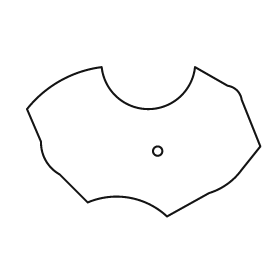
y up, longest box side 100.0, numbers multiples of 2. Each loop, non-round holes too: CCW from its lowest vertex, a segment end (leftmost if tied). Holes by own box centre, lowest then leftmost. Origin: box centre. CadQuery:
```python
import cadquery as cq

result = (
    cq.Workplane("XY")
    .moveTo(10.0, -32.0)
    .lineTo(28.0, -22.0)
    .threePointArc((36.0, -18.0), (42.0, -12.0))
    .lineTo(50.0, -2.0)
    .lineTo(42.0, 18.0)
    .threePointArc((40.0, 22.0), (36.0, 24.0))
    .lineTo(22.0, 32.0)
    .threePointArc((2.0, 14.0), (-18.0, 32.0))
    .threePointArc((-36.0, 26.0), (-50.0, 14.0))
    .lineTo(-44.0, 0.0)
    .threePointArc((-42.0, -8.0), (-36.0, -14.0))
    .lineTo(-24.0, -26.0)
    .threePointArc((-6.0, -24.0), (10.0, -32.0))
    .close()
    .moveTo(6.0, -4.0)
    .circle(2.0)
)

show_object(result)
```